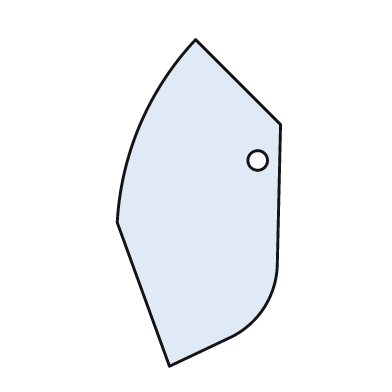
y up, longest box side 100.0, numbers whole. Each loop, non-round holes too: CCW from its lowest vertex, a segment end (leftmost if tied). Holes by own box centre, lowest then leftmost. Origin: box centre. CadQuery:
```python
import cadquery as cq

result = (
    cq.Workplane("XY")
    .moveTo(-9.0, -50.0)
    .lineTo(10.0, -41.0)
    .threePointArc((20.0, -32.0), (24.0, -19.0))
    .lineTo(25.0, 24.0)
    .lineTo(-1.0, 50.0)
    .threePointArc((-18.0, 24.0), (-25.0, -6.0))
    .close()
    .moveTo(18.0, 13.0)
    .circle(3.0)
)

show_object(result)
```